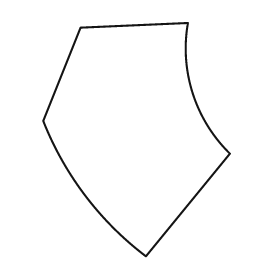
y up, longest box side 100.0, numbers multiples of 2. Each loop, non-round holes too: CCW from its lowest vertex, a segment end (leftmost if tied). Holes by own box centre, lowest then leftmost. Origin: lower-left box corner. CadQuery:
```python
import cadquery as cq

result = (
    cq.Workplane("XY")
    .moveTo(44.0, 0.0)
    .lineTo(80.0, 44.0)
    .threePointArc((64.0, 70.0), (62.0, 100.0))
    .lineTo(16.0, 98.0)
    .lineTo(0.0, 58.0)
    .threePointArc((18.0, 26.0), (44.0, 0.0))
    .close()
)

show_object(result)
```